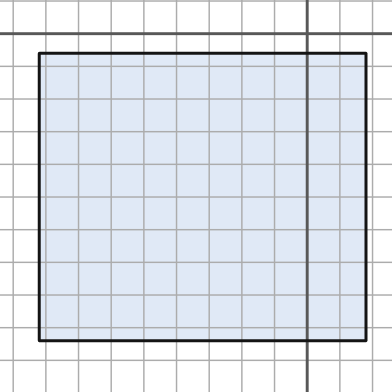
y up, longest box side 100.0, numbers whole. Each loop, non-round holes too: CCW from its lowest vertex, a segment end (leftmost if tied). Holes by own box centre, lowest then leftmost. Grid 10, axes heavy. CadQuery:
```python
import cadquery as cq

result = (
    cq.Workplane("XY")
    .moveTo(-82.0, -94.0)
    .lineTo(18.0, -94.0)
    .lineTo(18.0, -6.0)
    .lineTo(-82.0, -6.0)
    .close()
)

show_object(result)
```